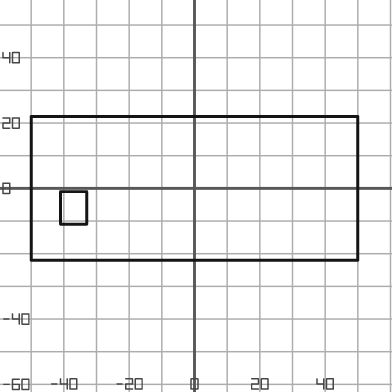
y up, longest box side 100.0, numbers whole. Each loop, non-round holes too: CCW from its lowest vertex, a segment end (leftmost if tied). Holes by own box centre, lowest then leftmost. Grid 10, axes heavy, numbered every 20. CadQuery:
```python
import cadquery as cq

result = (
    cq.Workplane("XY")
    .moveTo(-50.0, -22.0)
    .lineTo(50.0, -22.0)
    .lineTo(50.0, 22.0)
    .lineTo(-50.0, 22.0)
    .close()
    .moveTo(-41.0, -11.0)
    .lineTo(-33.0, -11.0)
    .lineTo(-33.0, -1.0)
    .lineTo(-41.0, -1.0)
    .close()
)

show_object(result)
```